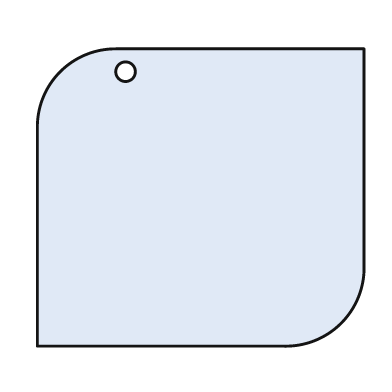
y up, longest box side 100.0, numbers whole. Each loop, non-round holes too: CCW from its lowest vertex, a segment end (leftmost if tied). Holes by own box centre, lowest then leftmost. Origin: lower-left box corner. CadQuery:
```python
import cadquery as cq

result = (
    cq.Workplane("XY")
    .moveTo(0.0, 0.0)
    .lineTo(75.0, 0.0)
    .threePointArc((93.0, 7.0), (100.0, 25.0))
    .lineTo(100.0, 91.0)
    .lineTo(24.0, 91.0)
    .threePointArc((7.0, 84.0), (0.0, 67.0))
    .close()
    .moveTo(27.0, 84.0)
    .circle(3.0)
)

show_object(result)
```